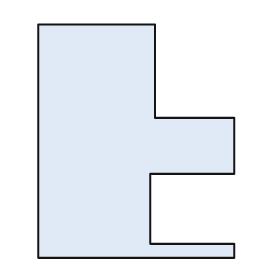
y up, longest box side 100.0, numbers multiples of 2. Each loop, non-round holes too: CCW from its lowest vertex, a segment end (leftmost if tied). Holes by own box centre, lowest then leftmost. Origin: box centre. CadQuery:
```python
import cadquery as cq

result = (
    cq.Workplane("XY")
    .moveTo(-42.0, -50.0)
    .lineTo(42.0, -50.0)
    .lineTo(42.0, -44.0)
    .lineTo(6.0, -44.0)
    .lineTo(6.0, -14.0)
    .lineTo(42.0, -14.0)
    .lineTo(42.0, 10.0)
    .lineTo(8.0, 10.0)
    .lineTo(8.0, 50.0)
    .lineTo(-42.0, 50.0)
    .close()
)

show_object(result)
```